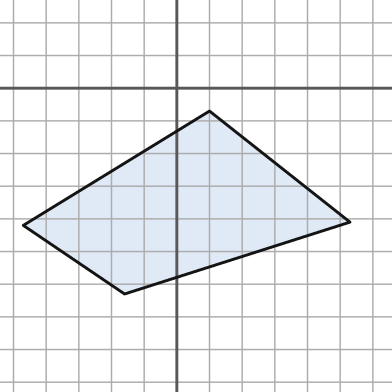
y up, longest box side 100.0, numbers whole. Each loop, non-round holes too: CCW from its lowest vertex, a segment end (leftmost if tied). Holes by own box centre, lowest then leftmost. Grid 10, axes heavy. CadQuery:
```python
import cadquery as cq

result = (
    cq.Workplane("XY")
    .moveTo(-16.0, -63.0)
    .lineTo(53.0, -41.0)
    .lineTo(10.0, -7.0)
    .lineTo(-47.0, -42.0)
    .close()
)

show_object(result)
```